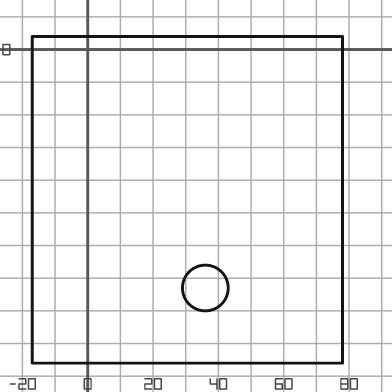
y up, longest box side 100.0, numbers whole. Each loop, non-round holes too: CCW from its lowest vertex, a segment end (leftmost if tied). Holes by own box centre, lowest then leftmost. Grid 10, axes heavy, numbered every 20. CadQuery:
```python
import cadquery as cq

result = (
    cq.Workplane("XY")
    .moveTo(-17.0, -96.0)
    .lineTo(78.0, -96.0)
    .lineTo(78.0, 4.0)
    .lineTo(-17.0, 4.0)
    .close()
    .moveTo(36.0, -73.0)
    .circle(7.0)
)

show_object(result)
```